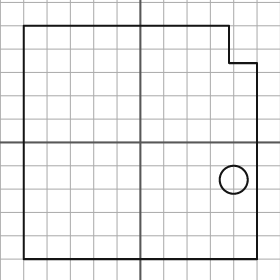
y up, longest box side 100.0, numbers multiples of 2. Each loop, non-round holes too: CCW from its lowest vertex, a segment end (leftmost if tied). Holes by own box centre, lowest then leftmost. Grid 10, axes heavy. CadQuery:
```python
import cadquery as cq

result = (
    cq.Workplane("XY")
    .moveTo(-50.0, -50.0)
    .lineTo(50.0, -50.0)
    .lineTo(50.0, 34.0)
    .lineTo(38.0, 34.0)
    .lineTo(38.0, 50.0)
    .lineTo(-50.0, 50.0)
    .close()
    .moveTo(40.0, -16.0)
    .circle(6.0)
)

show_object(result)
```